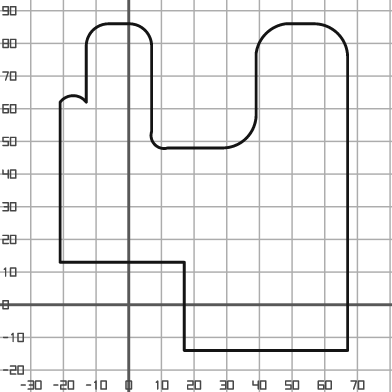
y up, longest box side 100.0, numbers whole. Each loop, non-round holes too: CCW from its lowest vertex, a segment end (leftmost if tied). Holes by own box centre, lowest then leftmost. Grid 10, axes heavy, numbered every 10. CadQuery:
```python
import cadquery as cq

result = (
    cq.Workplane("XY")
    .moveTo(17.0, -14.0)
    .lineTo(67.0, -14.0)
    .lineTo(67.0, 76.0)
    .threePointArc((64.0, 83.0), (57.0, 86.0))
    .lineTo(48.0, 86.0)
    .threePointArc((42.0, 83.0), (39.0, 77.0))
    .lineTo(39.0, 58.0)
    .threePointArc((36.0, 51.0), (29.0, 48.0))
    .lineTo(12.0, 48.0)
    .threePointArc((8.0, 49.0), (7.0, 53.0))
    .lineTo(7.0, 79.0)
    .threePointArc((5.0, 84.0), (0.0, 86.0))
    .lineTo(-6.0, 86.0)
    .threePointArc((-11.0, 84.0), (-13.0, 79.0))
    .lineTo(-13.0, 62.0)
    .threePointArc((-17.0, 64.0), (-21.0, 62.0))
    .lineTo(-21.0, 13.0)
    .lineTo(17.0, 13.0)
    .close()
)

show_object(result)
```